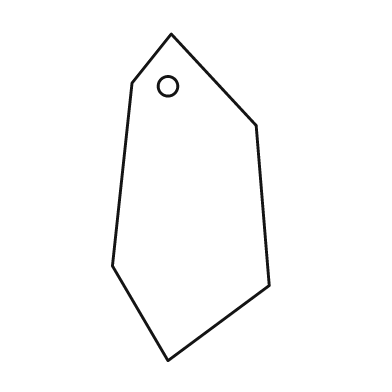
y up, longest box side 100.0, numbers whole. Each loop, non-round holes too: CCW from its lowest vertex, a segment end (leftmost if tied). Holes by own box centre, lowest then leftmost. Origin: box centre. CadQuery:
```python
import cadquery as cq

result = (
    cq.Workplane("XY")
    .moveTo(-7.0, -50.0)
    .lineTo(24.0, -27.0)
    .lineTo(20.0, 22.0)
    .lineTo(-6.0, 50.0)
    .lineTo(-18.0, 35.0)
    .lineTo(-24.0, -21.0)
    .close()
    .moveTo(-7.0, 34.0)
    .circle(3.0)
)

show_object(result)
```